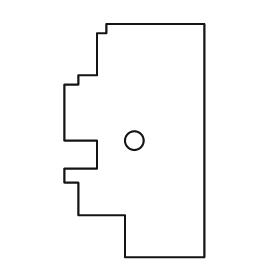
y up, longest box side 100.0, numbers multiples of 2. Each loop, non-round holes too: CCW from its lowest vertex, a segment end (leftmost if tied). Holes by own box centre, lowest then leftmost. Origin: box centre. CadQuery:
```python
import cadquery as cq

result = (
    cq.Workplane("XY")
    .moveTo(-4.0, -50.0)
    .lineTo(30.0, -50.0)
    .lineTo(30.0, 50.0)
    .lineTo(-12.0, 50.0)
    .lineTo(-12.0, 46.0)
    .lineTo(-16.0, 46.0)
    .lineTo(-16.0, 28.0)
    .lineTo(-24.0, 28.0)
    .lineTo(-24.0, 24.0)
    .lineTo(-30.0, 24.0)
    .lineTo(-30.0, 0.0)
    .lineTo(-16.0, 0.0)
    .lineTo(-16.0, -12.0)
    .lineTo(-30.0, -12.0)
    .lineTo(-30.0, -18.0)
    .lineTo(-24.0, -18.0)
    .lineTo(-24.0, -32.0)
    .lineTo(-4.0, -32.0)
    .close()
    .moveTo(0.0, 0.0)
    .circle(4.0)
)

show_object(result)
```